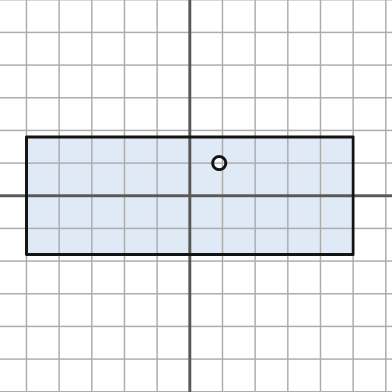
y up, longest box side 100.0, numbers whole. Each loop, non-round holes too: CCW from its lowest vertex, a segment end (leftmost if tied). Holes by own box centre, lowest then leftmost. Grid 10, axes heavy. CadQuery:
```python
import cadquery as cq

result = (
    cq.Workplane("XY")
    .moveTo(-50.0, -18.0)
    .lineTo(50.0, -18.0)
    .lineTo(50.0, 18.0)
    .lineTo(-50.0, 18.0)
    .close()
    .moveTo(9.0, 10.0)
    .circle(2.0)
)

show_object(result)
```